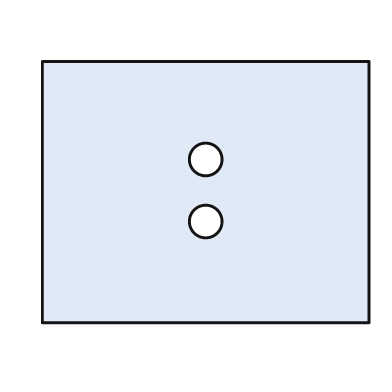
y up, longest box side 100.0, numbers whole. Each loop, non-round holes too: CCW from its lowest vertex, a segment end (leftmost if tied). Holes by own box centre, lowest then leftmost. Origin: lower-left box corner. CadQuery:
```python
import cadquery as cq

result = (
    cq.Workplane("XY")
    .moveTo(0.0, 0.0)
    .lineTo(100.0, 0.0)
    .lineTo(100.0, 80.0)
    .lineTo(0.0, 80.0)
    .close()
    .moveTo(50.0, 31.0)
    .circle(5.0)
    .moveTo(50.0, 50.0)
    .circle(5.0)
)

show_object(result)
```